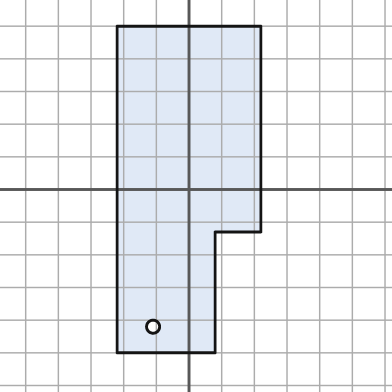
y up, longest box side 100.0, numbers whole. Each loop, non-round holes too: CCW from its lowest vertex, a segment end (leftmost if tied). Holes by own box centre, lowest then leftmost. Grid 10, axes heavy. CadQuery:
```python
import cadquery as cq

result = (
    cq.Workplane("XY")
    .moveTo(-22.0, -50.0)
    .lineTo(8.0, -50.0)
    .lineTo(8.0, -13.0)
    .lineTo(22.0, -13.0)
    .lineTo(22.0, 50.0)
    .lineTo(-22.0, 50.0)
    .close()
    .moveTo(-11.0, -42.0)
    .circle(2.0)
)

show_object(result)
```